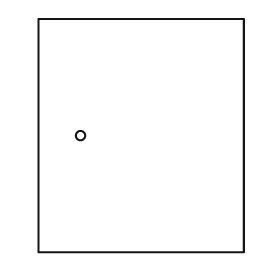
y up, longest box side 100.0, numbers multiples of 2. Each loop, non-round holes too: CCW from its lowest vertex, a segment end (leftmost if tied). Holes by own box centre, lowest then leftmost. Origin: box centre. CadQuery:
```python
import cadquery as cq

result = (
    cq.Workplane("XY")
    .moveTo(-44.0, -50.0)
    .lineTo(44.0, -50.0)
    .lineTo(44.0, 50.0)
    .lineTo(-44.0, 50.0)
    .close()
    .moveTo(-26.0, 0.0)
    .circle(2.0)
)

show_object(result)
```